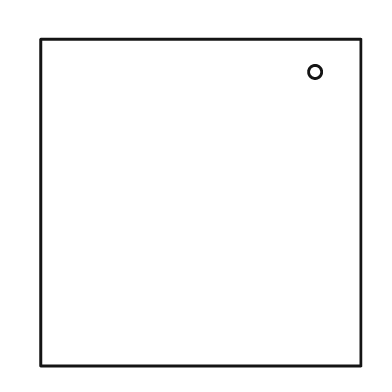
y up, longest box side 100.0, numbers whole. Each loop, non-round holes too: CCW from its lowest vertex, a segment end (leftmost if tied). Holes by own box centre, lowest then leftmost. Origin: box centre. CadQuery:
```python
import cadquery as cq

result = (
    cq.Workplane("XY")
    .moveTo(-49.0, -50.0)
    .lineTo(49.0, -50.0)
    .lineTo(49.0, 50.0)
    .lineTo(-49.0, 50.0)
    .close()
    .moveTo(35.0, 40.0)
    .circle(2.0)
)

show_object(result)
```